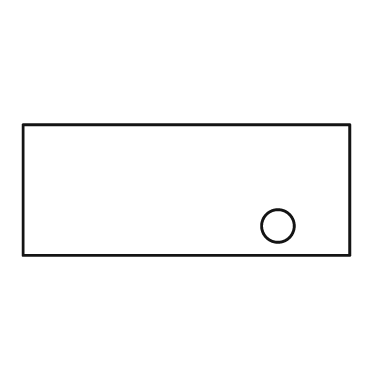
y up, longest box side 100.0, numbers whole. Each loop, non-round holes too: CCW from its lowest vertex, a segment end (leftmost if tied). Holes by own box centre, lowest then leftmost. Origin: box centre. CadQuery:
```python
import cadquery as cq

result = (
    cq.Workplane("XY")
    .moveTo(-50.0, -20.0)
    .lineTo(50.0, -20.0)
    .lineTo(50.0, 20.0)
    .lineTo(-50.0, 20.0)
    .close()
    .moveTo(28.0, -11.0)
    .circle(5.0)
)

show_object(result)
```